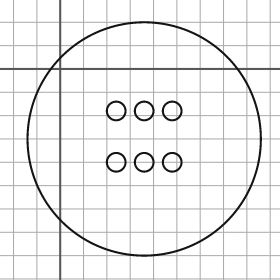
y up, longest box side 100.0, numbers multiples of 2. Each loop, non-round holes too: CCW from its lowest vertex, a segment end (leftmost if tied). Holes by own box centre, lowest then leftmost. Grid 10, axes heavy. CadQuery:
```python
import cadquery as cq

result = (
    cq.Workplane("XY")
    .moveTo(36.0, -30.0)
    .circle(50.0)
    .moveTo(24.0, -40.0)
    .circle(4.0)
    .moveTo(36.0, -40.0)
    .circle(4.0)
    .moveTo(48.0, -40.0)
    .circle(4.0)
    .moveTo(24.0, -18.0)
    .circle(4.0)
    .moveTo(36.0, -18.0)
    .circle(4.0)
    .moveTo(48.0, -18.0)
    .circle(4.0)
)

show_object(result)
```